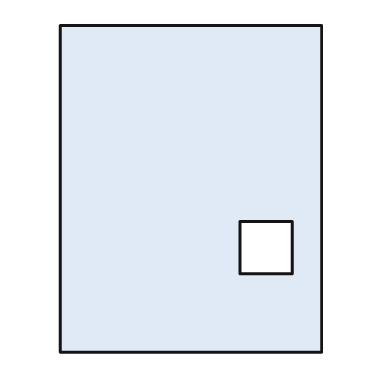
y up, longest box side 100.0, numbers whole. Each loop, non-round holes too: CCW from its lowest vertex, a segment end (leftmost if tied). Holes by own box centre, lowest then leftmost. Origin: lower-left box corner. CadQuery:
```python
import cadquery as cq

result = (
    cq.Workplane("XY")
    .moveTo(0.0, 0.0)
    .lineTo(80.0, 0.0)
    .lineTo(80.0, 100.0)
    .lineTo(0.0, 100.0)
    .close()
    .moveTo(55.0, 24.0)
    .lineTo(71.0, 24.0)
    .lineTo(71.0, 40.0)
    .lineTo(55.0, 40.0)
    .close()
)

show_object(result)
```